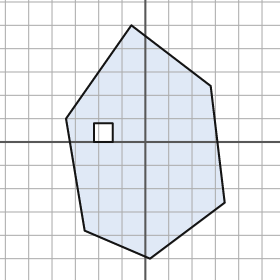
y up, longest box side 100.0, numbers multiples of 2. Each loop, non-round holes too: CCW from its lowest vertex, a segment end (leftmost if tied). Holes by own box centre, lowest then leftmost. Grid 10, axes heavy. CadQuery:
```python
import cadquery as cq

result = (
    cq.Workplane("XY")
    .moveTo(2.0, -50.0)
    .lineTo(34.0, -26.0)
    .lineTo(28.0, 24.0)
    .lineTo(-6.0, 50.0)
    .lineTo(-34.0, 10.0)
    .lineTo(-26.0, -38.0)
    .close()
    .moveTo(-22.0, 0.0)
    .lineTo(-14.0, 0.0)
    .lineTo(-14.0, 8.0)
    .lineTo(-22.0, 8.0)
    .close()
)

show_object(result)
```